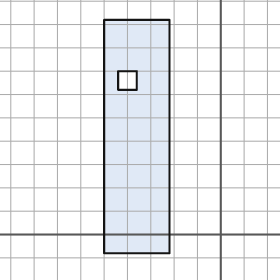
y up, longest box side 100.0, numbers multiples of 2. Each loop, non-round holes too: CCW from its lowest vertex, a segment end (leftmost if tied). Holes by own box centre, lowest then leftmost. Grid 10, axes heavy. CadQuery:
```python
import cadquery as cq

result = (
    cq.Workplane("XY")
    .moveTo(-50.0, -8.0)
    .lineTo(-22.0, -8.0)
    .lineTo(-22.0, 92.0)
    .lineTo(-50.0, 92.0)
    .close()
    .moveTo(-44.0, 62.0)
    .lineTo(-36.0, 62.0)
    .lineTo(-36.0, 70.0)
    .lineTo(-44.0, 70.0)
    .close()
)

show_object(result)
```